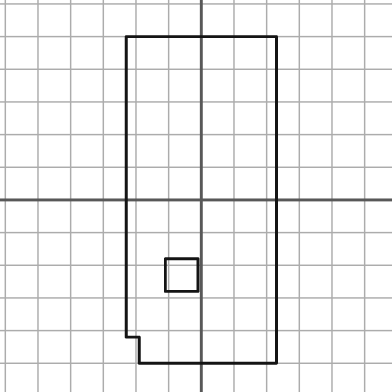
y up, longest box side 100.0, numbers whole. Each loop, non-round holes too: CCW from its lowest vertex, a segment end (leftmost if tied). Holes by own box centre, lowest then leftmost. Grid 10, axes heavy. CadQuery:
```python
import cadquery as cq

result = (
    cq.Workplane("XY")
    .moveTo(-19.0, -50.0)
    .lineTo(23.0, -50.0)
    .lineTo(23.0, 50.0)
    .lineTo(-23.0, 50.0)
    .lineTo(-23.0, -42.0)
    .lineTo(-19.0, -42.0)
    .close()
    .moveTo(-11.0, -28.0)
    .lineTo(-1.0, -28.0)
    .lineTo(-1.0, -18.0)
    .lineTo(-11.0, -18.0)
    .close()
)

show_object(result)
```